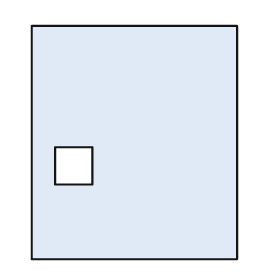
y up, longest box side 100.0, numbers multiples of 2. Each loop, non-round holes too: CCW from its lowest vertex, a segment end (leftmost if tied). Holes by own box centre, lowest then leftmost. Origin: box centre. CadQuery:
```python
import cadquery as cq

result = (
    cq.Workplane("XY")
    .moveTo(-44.0, -50.0)
    .lineTo(44.0, -50.0)
    .lineTo(44.0, 50.0)
    .lineTo(-44.0, 50.0)
    .close()
    .moveTo(-34.0, -18.0)
    .lineTo(-18.0, -18.0)
    .lineTo(-18.0, -2.0)
    .lineTo(-34.0, -2.0)
    .close()
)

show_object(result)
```